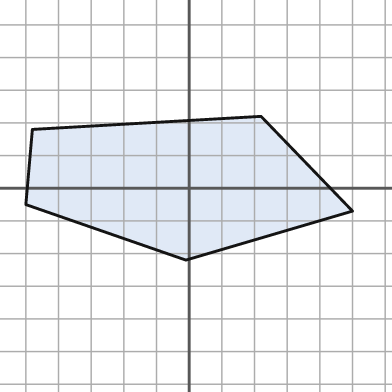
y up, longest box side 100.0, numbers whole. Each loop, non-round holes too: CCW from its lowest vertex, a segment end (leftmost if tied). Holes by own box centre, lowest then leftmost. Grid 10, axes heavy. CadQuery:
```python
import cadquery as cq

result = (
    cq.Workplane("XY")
    .moveTo(-1.0, -22.0)
    .lineTo(50.0, -7.0)
    .lineTo(22.0, 22.0)
    .lineTo(-48.0, 18.0)
    .lineTo(-50.0, -5.0)
    .close()
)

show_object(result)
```